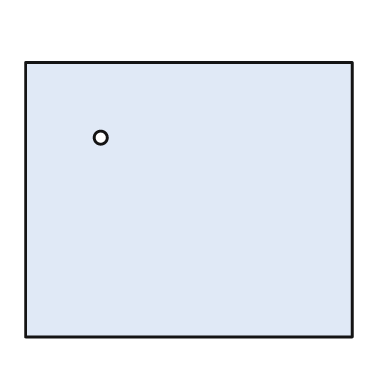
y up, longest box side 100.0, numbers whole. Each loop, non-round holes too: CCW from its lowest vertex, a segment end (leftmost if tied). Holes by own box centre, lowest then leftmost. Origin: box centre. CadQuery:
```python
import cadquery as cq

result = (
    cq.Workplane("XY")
    .moveTo(-50.0, -42.0)
    .lineTo(50.0, -42.0)
    .lineTo(50.0, 42.0)
    .lineTo(-50.0, 42.0)
    .close()
    .moveTo(-27.0, 19.0)
    .circle(2.0)
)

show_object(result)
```